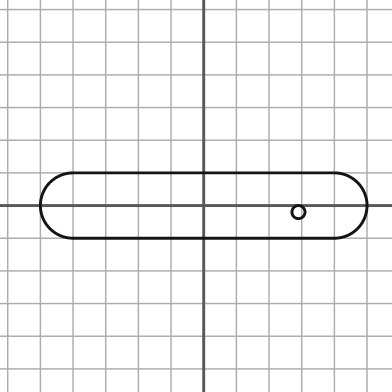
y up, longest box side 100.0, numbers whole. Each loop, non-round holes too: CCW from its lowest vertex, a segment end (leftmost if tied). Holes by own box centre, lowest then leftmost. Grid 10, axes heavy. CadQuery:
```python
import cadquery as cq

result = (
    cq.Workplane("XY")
    .moveTo(-40.0, -10.0)
    .lineTo(40.0, -10.0)
    .threePointArc((50.0, 0.0), (40.0, 10.0))
    .lineTo(-40.0, 10.0)
    .threePointArc((-50.0, 0.0), (-40.0, -10.0))
    .close()
    .moveTo(29.0, -2.0)
    .circle(2.0)
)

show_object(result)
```